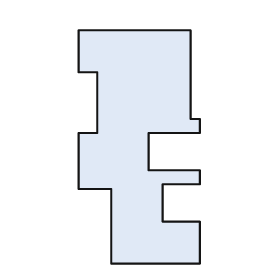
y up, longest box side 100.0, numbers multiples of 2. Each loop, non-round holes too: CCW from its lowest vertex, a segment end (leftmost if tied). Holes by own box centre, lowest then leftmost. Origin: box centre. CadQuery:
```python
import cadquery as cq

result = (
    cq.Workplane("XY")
    .moveTo(-12.0, -50.0)
    .lineTo(26.0, -50.0)
    .lineTo(26.0, -32.0)
    .lineTo(10.0, -32.0)
    .lineTo(10.0, -16.0)
    .lineTo(26.0, -16.0)
    .lineTo(26.0, -10.0)
    .lineTo(4.0, -10.0)
    .lineTo(4.0, 6.0)
    .lineTo(26.0, 6.0)
    .lineTo(26.0, 12.0)
    .lineTo(22.0, 12.0)
    .lineTo(22.0, 50.0)
    .lineTo(-26.0, 50.0)
    .lineTo(-26.0, 32.0)
    .lineTo(-18.0, 32.0)
    .lineTo(-18.0, 6.0)
    .lineTo(-26.0, 6.0)
    .lineTo(-26.0, -18.0)
    .lineTo(-12.0, -18.0)
    .close()
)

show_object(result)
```